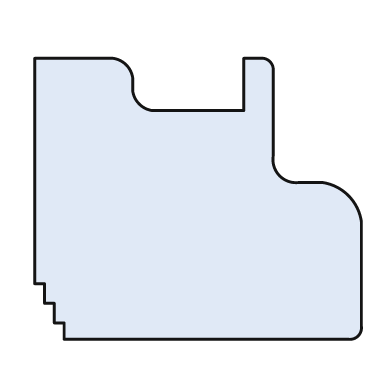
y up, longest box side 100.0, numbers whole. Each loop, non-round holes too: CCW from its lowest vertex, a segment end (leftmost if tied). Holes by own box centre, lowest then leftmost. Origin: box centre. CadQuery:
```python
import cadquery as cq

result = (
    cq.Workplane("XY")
    .moveTo(-41.0, -43.0)
    .lineTo(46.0, -43.0)
    .threePointArc((49.0, -42.0), (50.0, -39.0))
    .lineTo(50.0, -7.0)
    .threePointArc((46.0, 1.0), (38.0, 5.0))
    .lineTo(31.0, 5.0)
    .threePointArc((25.0, 7.0), (23.0, 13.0))
    .lineTo(23.0, 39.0)
    .threePointArc((22.0, 42.0), (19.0, 43.0))
    .lineTo(14.0, 43.0)
    .lineTo(14.0, 27.0)
    .lineTo(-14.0, 27.0)
    .threePointArc((-18.0, 29.0), (-20.0, 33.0))
    .lineTo(-20.0, 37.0)
    .threePointArc((-22.0, 41.0), (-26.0, 43.0))
    .lineTo(-50.0, 43.0)
    .lineTo(-50.0, -26.0)
    .lineTo(-47.0, -26.0)
    .lineTo(-47.0, -32.0)
    .lineTo(-44.0, -32.0)
    .lineTo(-44.0, -38.0)
    .lineTo(-41.0, -38.0)
    .close()
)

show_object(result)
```